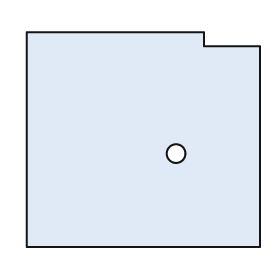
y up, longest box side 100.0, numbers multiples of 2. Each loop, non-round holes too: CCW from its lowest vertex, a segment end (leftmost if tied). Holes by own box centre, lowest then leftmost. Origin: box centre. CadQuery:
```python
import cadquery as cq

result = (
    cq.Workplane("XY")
    .moveTo(-50.0, -46.0)
    .lineTo(50.0, -46.0)
    .lineTo(50.0, 40.0)
    .lineTo(26.0, 40.0)
    .lineTo(26.0, 46.0)
    .lineTo(-50.0, 46.0)
    .close()
    .moveTo(14.0, -6.0)
    .circle(4.0)
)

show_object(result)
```